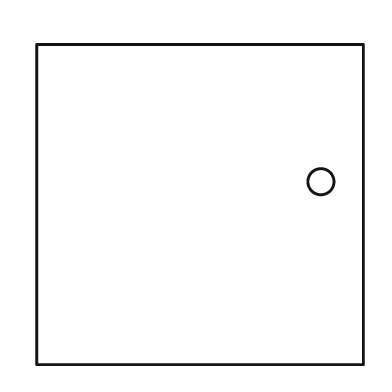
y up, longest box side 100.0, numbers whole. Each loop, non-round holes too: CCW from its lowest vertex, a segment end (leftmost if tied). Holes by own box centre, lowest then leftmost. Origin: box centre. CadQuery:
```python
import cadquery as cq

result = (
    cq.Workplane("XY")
    .moveTo(-50.0, -49.0)
    .lineTo(50.0, -49.0)
    .lineTo(50.0, 49.0)
    .lineTo(-50.0, 49.0)
    .close()
    .moveTo(37.0, 7.0)
    .circle(4.0)
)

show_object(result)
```